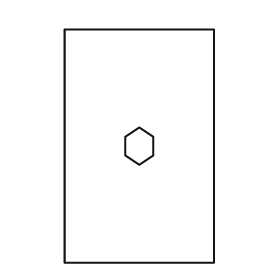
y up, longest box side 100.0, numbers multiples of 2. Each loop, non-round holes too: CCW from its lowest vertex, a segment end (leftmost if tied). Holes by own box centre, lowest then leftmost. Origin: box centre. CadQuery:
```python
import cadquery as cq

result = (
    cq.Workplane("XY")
    .moveTo(-32.0, -50.0)
    .lineTo(32.0, -50.0)
    .lineTo(32.0, 50.0)
    .lineTo(-32.0, 50.0)
    .close()
    .moveTo(0.0, -8.0)
    .lineTo(6.0, -4.0)
    .lineTo(6.0, 4.0)
    .lineTo(0.0, 8.0)
    .lineTo(-6.0, 4.0)
    .lineTo(-6.0, -4.0)
    .close()
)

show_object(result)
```